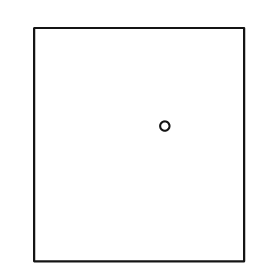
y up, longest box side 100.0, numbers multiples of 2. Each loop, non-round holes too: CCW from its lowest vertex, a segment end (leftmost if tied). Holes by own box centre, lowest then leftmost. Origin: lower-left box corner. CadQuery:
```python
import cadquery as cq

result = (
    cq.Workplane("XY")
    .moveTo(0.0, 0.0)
    .lineTo(90.0, 0.0)
    .lineTo(90.0, 100.0)
    .lineTo(0.0, 100.0)
    .close()
    .moveTo(56.0, 58.0)
    .circle(2.0)
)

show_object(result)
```